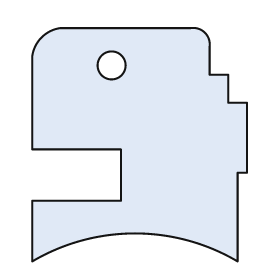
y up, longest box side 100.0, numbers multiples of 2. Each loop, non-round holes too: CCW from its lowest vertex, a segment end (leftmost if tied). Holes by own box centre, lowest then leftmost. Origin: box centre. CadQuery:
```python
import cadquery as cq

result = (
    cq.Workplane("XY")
    .moveTo(-46.0, -50.0)
    .threePointArc((-2.0, -38.0), (42.0, -50.0))
    .lineTo(42.0, -12.0)
    .lineTo(46.0, -12.0)
    .lineTo(46.0, 18.0)
    .lineTo(38.0, 18.0)
    .lineTo(38.0, 30.0)
    .lineTo(30.0, 30.0)
    .lineTo(30.0, 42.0)
    .threePointArc((28.0, 48.0), (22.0, 50.0))
    .lineTo(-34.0, 50.0)
    .threePointArc((-42.0, 46.0), (-46.0, 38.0))
    .lineTo(-46.0, -2.0)
    .lineTo(-8.0, -2.0)
    .lineTo(-8.0, -24.0)
    .lineTo(-46.0, -24.0)
    .close()
    .moveTo(-12.0, 34.0)
    .circle(6.0)
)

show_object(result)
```